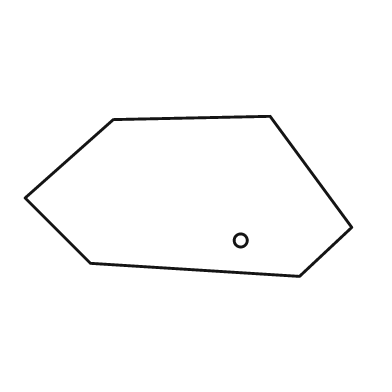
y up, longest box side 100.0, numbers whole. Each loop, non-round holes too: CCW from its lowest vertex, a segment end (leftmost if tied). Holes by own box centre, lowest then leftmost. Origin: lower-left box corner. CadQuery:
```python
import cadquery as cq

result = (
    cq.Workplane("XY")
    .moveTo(84.0, 0.0)
    .lineTo(100.0, 15.0)
    .lineTo(75.0, 49.0)
    .lineTo(27.0, 48.0)
    .lineTo(0.0, 24.0)
    .lineTo(20.0, 4.0)
    .close()
    .moveTo(66.0, 11.0)
    .circle(2.0)
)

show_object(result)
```